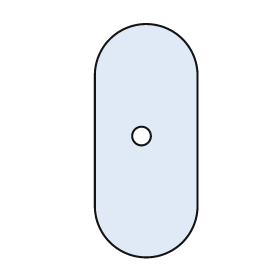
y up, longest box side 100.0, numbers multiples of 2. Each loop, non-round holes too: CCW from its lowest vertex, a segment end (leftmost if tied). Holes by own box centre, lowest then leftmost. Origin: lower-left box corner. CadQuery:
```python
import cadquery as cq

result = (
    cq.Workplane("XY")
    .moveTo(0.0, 22.0)
    .threePointArc((22.0, 0.0), (44.0, 22.0))
    .lineTo(44.0, 78.0)
    .threePointArc((22.0, 100.0), (0.0, 78.0))
    .close()
    .moveTo(20.0, 52.0)
    .circle(4.0)
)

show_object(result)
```